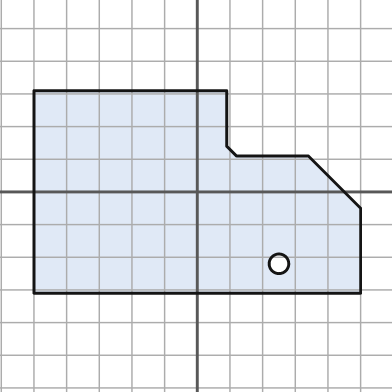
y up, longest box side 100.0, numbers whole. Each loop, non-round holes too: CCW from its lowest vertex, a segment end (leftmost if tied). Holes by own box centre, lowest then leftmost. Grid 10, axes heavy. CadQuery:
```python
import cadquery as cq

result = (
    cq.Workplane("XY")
    .moveTo(-50.0, -31.0)
    .lineTo(50.0, -31.0)
    .lineTo(50.0, -5.0)
    .lineTo(34.0, 11.0)
    .lineTo(12.0, 11.0)
    .lineTo(9.0, 14.0)
    .lineTo(9.0, 31.0)
    .lineTo(-50.0, 31.0)
    .close()
    .moveTo(25.0, -22.0)
    .circle(3.0)
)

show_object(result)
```